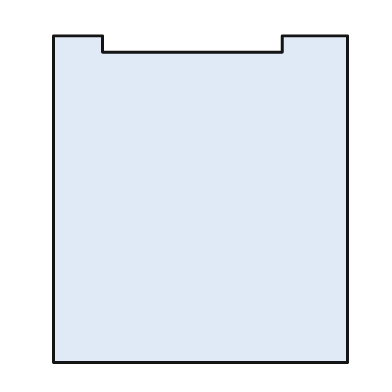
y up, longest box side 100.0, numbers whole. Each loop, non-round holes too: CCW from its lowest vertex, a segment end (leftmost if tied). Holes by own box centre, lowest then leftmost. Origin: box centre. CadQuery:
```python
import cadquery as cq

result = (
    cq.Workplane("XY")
    .moveTo(-45.0, -50.0)
    .lineTo(45.0, -50.0)
    .lineTo(45.0, 50.0)
    .lineTo(25.0, 50.0)
    .lineTo(25.0, 45.0)
    .lineTo(-30.0, 45.0)
    .lineTo(-30.0, 50.0)
    .lineTo(-45.0, 50.0)
    .close()
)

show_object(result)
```